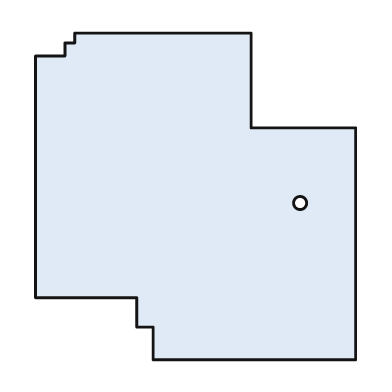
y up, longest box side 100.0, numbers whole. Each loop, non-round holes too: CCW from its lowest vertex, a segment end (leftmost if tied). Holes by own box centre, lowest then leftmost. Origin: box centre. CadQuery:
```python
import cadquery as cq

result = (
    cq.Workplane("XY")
    .moveTo(-13.0, -50.0)
    .lineTo(49.0, -50.0)
    .lineTo(49.0, 21.0)
    .lineTo(17.0, 21.0)
    .lineTo(17.0, 50.0)
    .lineTo(-37.0, 50.0)
    .lineTo(-37.0, 47.0)
    .lineTo(-40.0, 47.0)
    .lineTo(-40.0, 43.0)
    .lineTo(-49.0, 43.0)
    .lineTo(-49.0, -31.0)
    .lineTo(-18.0, -31.0)
    .lineTo(-18.0, -40.0)
    .lineTo(-13.0, -40.0)
    .close()
    .moveTo(32.0, -2.0)
    .circle(2.0)
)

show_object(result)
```